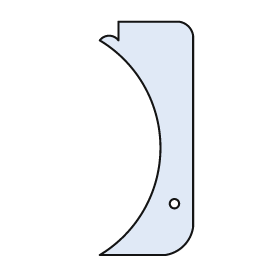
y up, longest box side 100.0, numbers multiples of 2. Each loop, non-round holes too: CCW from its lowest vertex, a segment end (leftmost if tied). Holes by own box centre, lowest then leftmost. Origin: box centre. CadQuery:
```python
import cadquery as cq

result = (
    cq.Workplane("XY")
    .moveTo(-20.0, -50.0)
    .lineTo(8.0, -50.0)
    .threePointArc((16.0, -46.0), (20.0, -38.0))
    .lineTo(20.0, 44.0)
    .threePointArc((18.0, 48.0), (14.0, 50.0))
    .lineTo(-12.0, 50.0)
    .lineTo(-12.0, 42.0)
    .threePointArc((-16.0, 44.0), (-20.0, 42.0))
    .threePointArc((6.0, -4.0), (-20.0, -50.0))
    .close()
    .moveTo(12.0, -28.0)
    .circle(2.0)
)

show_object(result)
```